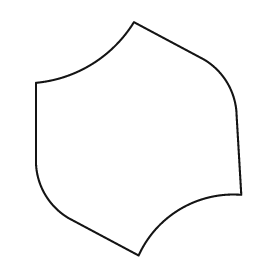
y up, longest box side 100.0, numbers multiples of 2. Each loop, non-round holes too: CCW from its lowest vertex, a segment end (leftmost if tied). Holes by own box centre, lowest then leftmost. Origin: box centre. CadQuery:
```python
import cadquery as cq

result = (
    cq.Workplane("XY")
    .moveTo(0.0, -50.0)
    .threePointArc((18.0, -30.0), (44.0, -24.0))
    .lineTo(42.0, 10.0)
    .threePointArc((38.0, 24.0), (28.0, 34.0))
    .lineTo(-2.0, 50.0)
    .threePointArc((-20.0, 32.0), (-44.0, 24.0))
    .lineTo(-44.0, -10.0)
    .threePointArc((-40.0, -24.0), (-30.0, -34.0))
    .close()
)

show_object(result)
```